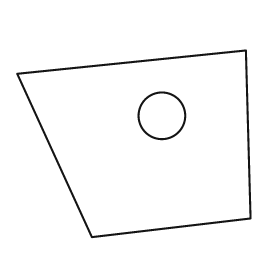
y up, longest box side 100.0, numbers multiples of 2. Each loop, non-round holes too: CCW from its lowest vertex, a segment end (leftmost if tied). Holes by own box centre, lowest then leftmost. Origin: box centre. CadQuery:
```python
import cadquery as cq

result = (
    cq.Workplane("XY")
    .moveTo(-18.0, -40.0)
    .lineTo(50.0, -32.0)
    .lineTo(48.0, 40.0)
    .lineTo(-50.0, 30.0)
    .close()
    .moveTo(12.0, 12.0)
    .circle(10.0)
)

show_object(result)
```